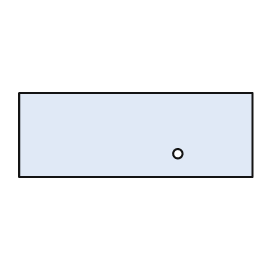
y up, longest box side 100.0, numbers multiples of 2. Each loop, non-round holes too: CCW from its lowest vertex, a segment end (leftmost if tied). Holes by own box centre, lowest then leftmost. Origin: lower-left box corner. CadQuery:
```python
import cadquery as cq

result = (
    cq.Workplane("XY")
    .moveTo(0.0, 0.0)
    .lineTo(100.0, 0.0)
    .lineTo(100.0, 36.0)
    .lineTo(0.0, 36.0)
    .close()
    .moveTo(68.0, 10.0)
    .circle(2.0)
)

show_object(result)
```